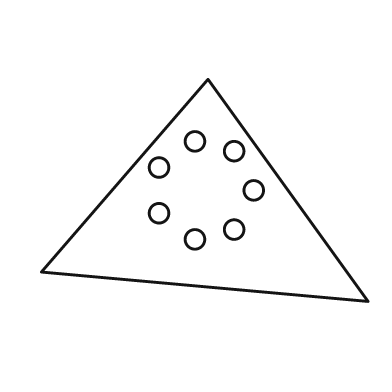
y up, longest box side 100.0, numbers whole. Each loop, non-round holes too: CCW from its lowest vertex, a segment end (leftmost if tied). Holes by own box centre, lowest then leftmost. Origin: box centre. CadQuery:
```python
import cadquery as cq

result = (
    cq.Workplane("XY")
    .moveTo(50.0, -34.0)
    .lineTo(1.0, 34.0)
    .lineTo(-50.0, -25.0)
    .close()
    .moveTo(-3.0, -15.0)
    .circle(3.0)
    .moveTo(9.0, -12.0)
    .circle(3.0)
    .moveTo(-14.0, -7.0)
    .circle(3.0)
    .moveTo(15.0, 0.0)
    .circle(3.0)
    .moveTo(-14.0, 7.0)
    .circle(3.0)
    .moveTo(9.0, 12.0)
    .circle(3.0)
    .moveTo(-3.0, 15.0)
    .circle(3.0)
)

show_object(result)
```